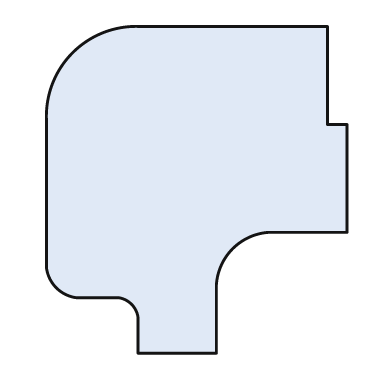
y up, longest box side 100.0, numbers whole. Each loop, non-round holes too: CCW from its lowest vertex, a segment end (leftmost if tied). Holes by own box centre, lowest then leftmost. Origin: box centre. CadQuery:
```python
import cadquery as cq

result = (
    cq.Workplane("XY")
    .moveTo(-18.0, -50.0)
    .lineTo(6.0, -50.0)
    .lineTo(6.0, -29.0)
    .threePointArc((11.0, -18.0), (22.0, -13.0))
    .lineTo(46.0, -13.0)
    .lineTo(46.0, 20.0)
    .lineTo(40.0, 20.0)
    .lineTo(40.0, 50.0)
    .lineTo(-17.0, 50.0)
    .threePointArc((-38.0, 42.0), (-46.0, 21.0))
    .lineTo(-46.0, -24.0)
    .threePointArc((-43.0, -30.0), (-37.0, -33.0))
    .lineTo(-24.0, -33.0)
    .threePointArc((-20.0, -35.0), (-18.0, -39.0))
    .close()
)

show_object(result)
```